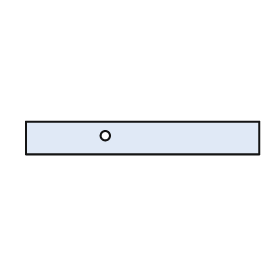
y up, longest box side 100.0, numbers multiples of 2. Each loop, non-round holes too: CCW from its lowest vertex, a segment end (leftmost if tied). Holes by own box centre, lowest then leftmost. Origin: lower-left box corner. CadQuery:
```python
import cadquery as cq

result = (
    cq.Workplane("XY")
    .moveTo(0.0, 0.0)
    .lineTo(100.0, 0.0)
    .lineTo(100.0, 14.0)
    .lineTo(0.0, 14.0)
    .close()
    .moveTo(34.0, 8.0)
    .circle(2.0)
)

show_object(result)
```